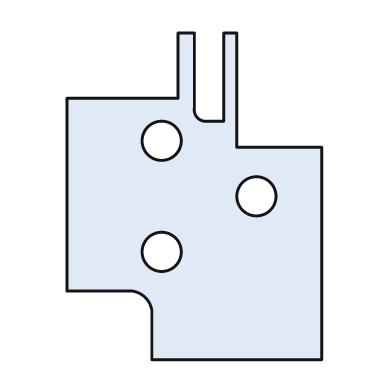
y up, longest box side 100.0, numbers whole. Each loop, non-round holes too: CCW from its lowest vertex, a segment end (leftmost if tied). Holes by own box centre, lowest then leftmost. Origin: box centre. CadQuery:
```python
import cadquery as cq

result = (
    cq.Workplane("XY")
    .moveTo(-13.0, -50.0)
    .lineTo(39.0, -50.0)
    .lineTo(39.0, 15.0)
    .lineTo(13.0, 15.0)
    .lineTo(13.0, 50.0)
    .lineTo(9.0, 50.0)
    .lineTo(9.0, 23.0)
    .lineTo(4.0, 23.0)
    .threePointArc((1.0, 24.0), (0.0, 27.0))
    .lineTo(0.0, 50.0)
    .lineTo(-5.0, 50.0)
    .lineTo(-5.0, 30.0)
    .lineTo(-39.0, 30.0)
    .lineTo(-39.0, -29.0)
    .lineTo(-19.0, -29.0)
    .threePointArc((-15.0, -31.0), (-13.0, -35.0))
    .close()
    .moveTo(-10.0, -17.0)
    .circle(6.0)
    .moveTo(19.0, 0.0)
    .circle(6.0)
    .moveTo(-10.0, 17.0)
    .circle(6.0)
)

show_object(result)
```